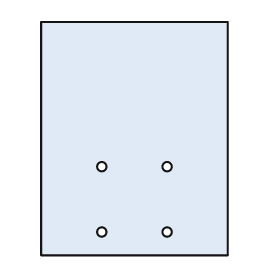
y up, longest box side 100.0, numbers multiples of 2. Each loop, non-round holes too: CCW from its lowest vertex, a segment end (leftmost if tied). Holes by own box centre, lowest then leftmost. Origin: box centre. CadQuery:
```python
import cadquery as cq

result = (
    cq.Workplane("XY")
    .moveTo(-40.0, -50.0)
    .lineTo(40.0, -50.0)
    .lineTo(40.0, 50.0)
    .lineTo(-40.0, 50.0)
    .close()
    .moveTo(-14.0, -40.0)
    .circle(2.0)
    .moveTo(14.0, -40.0)
    .circle(2.0)
    .moveTo(-14.0, -12.0)
    .circle(2.0)
    .moveTo(14.0, -12.0)
    .circle(2.0)
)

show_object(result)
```